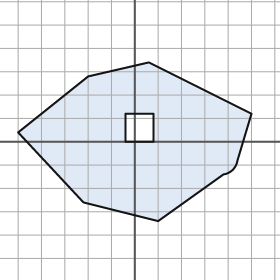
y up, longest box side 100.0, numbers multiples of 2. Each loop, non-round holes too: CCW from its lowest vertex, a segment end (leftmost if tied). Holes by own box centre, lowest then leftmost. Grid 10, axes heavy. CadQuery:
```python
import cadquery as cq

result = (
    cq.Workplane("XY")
    .moveTo(10.0, -34.0)
    .lineTo(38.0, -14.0)
    .threePointArc((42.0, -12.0), (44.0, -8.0))
    .lineTo(50.0, 12.0)
    .lineTo(6.0, 34.0)
    .lineTo(-20.0, 28.0)
    .lineTo(-50.0, 4.0)
    .lineTo(-22.0, -26.0)
    .close()
    .moveTo(-4.0, 0.0)
    .lineTo(8.0, 0.0)
    .lineTo(8.0, 12.0)
    .lineTo(-4.0, 12.0)
    .close()
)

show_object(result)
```